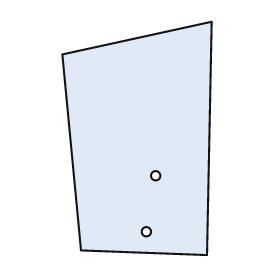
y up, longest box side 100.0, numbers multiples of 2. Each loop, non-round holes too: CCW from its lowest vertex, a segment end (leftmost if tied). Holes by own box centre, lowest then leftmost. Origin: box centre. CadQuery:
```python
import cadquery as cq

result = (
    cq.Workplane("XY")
    .moveTo(30.0, -50.0)
    .lineTo(32.0, 50.0)
    .lineTo(-32.0, 36.0)
    .lineTo(-24.0, -48.0)
    .close()
    .moveTo(4.0, -40.0)
    .circle(2.0)
    .moveTo(8.0, -16.0)
    .circle(2.0)
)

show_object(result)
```